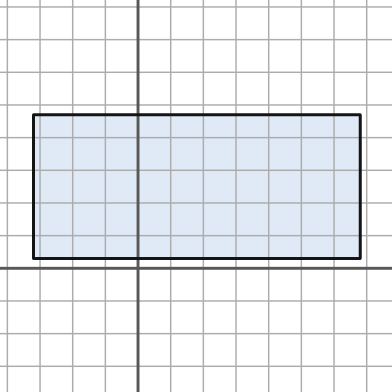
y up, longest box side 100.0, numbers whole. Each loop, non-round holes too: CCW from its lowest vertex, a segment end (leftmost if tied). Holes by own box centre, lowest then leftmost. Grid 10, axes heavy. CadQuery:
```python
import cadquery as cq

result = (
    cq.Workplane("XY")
    .moveTo(-32.0, 3.0)
    .lineTo(68.0, 3.0)
    .lineTo(68.0, 47.0)
    .lineTo(-32.0, 47.0)
    .close()
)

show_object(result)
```